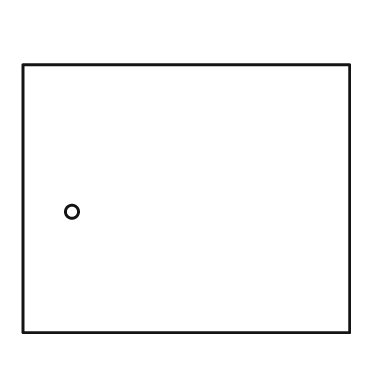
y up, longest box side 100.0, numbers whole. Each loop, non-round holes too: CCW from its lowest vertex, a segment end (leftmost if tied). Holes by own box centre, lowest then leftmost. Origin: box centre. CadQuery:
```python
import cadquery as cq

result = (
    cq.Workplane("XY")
    .moveTo(-50.0, -41.0)
    .lineTo(50.0, -41.0)
    .lineTo(50.0, 41.0)
    .lineTo(-50.0, 41.0)
    .close()
    .moveTo(-35.0, -4.0)
    .circle(2.0)
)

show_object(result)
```